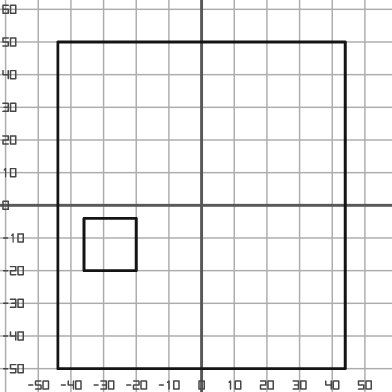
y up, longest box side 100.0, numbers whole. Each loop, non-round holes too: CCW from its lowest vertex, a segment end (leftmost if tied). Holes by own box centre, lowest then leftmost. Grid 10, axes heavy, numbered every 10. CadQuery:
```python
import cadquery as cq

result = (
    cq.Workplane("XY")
    .moveTo(-44.0, -50.0)
    .lineTo(44.0, -50.0)
    .lineTo(44.0, 50.0)
    .lineTo(-44.0, 50.0)
    .close()
    .moveTo(-36.0, -20.0)
    .lineTo(-20.0, -20.0)
    .lineTo(-20.0, -4.0)
    .lineTo(-36.0, -4.0)
    .close()
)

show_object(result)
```